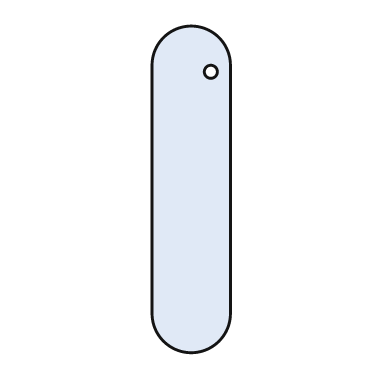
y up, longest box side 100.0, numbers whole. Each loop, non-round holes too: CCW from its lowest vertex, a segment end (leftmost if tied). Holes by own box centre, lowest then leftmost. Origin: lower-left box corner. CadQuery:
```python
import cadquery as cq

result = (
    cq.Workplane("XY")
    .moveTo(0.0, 12.0)
    .threePointArc((12.0, 0.0), (24.0, 12.0))
    .lineTo(24.0, 88.0)
    .threePointArc((12.0, 100.0), (0.0, 88.0))
    .close()
    .moveTo(18.0, 86.0)
    .circle(2.0)
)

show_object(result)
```